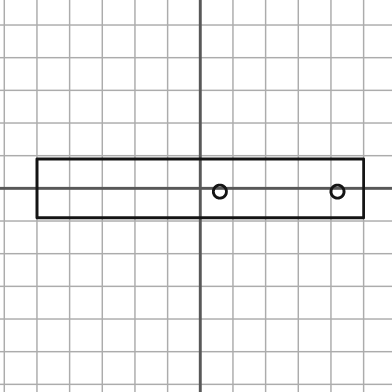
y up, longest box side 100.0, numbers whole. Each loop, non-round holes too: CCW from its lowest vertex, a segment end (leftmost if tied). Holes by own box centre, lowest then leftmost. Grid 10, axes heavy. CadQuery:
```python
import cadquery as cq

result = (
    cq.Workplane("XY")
    .moveTo(-50.0, -9.0)
    .lineTo(50.0, -9.0)
    .lineTo(50.0, 9.0)
    .lineTo(-50.0, 9.0)
    .close()
    .moveTo(6.0, -1.0)
    .circle(2.0)
    .moveTo(42.0, -1.0)
    .circle(2.0)
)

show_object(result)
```